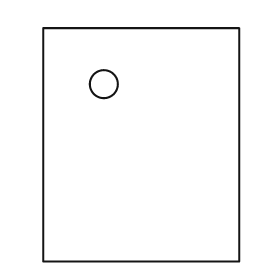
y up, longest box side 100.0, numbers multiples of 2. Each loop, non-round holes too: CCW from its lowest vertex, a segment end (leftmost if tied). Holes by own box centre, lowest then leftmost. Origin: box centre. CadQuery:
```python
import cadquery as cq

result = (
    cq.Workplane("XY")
    .moveTo(-42.0, -50.0)
    .lineTo(42.0, -50.0)
    .lineTo(42.0, 50.0)
    .lineTo(-42.0, 50.0)
    .close()
    .moveTo(-16.0, 26.0)
    .circle(6.0)
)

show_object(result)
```